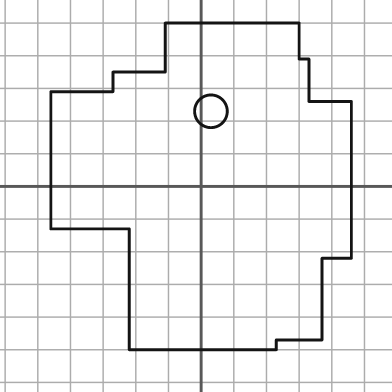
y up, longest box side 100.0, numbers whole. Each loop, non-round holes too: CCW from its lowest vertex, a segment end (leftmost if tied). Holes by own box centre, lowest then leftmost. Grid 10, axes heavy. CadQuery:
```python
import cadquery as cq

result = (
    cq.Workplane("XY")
    .moveTo(-22.0, -50.0)
    .lineTo(23.0, -50.0)
    .lineTo(23.0, -47.0)
    .lineTo(37.0, -47.0)
    .lineTo(37.0, -22.0)
    .lineTo(46.0, -22.0)
    .lineTo(46.0, 26.0)
    .lineTo(33.0, 26.0)
    .lineTo(33.0, 39.0)
    .lineTo(30.0, 39.0)
    .lineTo(30.0, 50.0)
    .lineTo(-11.0, 50.0)
    .lineTo(-11.0, 35.0)
    .lineTo(-27.0, 35.0)
    .lineTo(-27.0, 29.0)
    .lineTo(-46.0, 29.0)
    .lineTo(-46.0, -13.0)
    .lineTo(-22.0, -13.0)
    .close()
    .moveTo(3.0, 23.0)
    .circle(5.0)
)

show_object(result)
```